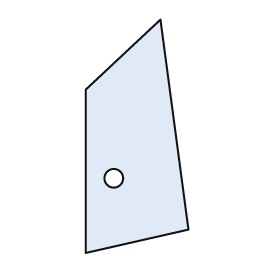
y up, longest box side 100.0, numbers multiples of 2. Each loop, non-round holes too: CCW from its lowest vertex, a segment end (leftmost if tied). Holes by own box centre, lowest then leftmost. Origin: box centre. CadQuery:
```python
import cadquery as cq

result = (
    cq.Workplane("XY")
    .moveTo(-22.0, -50.0)
    .lineTo(22.0, -40.0)
    .lineTo(10.0, 50.0)
    .lineTo(-22.0, 20.0)
    .close()
    .moveTo(-10.0, -18.0)
    .circle(4.0)
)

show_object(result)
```